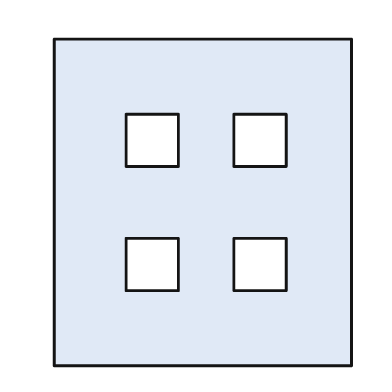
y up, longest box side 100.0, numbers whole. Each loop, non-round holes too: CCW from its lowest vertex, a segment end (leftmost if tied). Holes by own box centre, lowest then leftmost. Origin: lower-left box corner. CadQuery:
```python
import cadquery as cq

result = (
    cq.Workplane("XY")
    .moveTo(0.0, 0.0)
    .lineTo(91.0, 0.0)
    .lineTo(91.0, 100.0)
    .lineTo(0.0, 100.0)
    .close()
    .moveTo(22.0, 23.0)
    .lineTo(38.0, 23.0)
    .lineTo(38.0, 39.0)
    .lineTo(22.0, 39.0)
    .close()
    .moveTo(55.0, 23.0)
    .lineTo(71.0, 23.0)
    .lineTo(71.0, 39.0)
    .lineTo(55.0, 39.0)
    .close()
    .moveTo(22.0, 61.0)
    .lineTo(38.0, 61.0)
    .lineTo(38.0, 77.0)
    .lineTo(22.0, 77.0)
    .close()
    .moveTo(55.0, 61.0)
    .lineTo(71.0, 61.0)
    .lineTo(71.0, 77.0)
    .lineTo(55.0, 77.0)
    .close()
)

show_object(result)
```